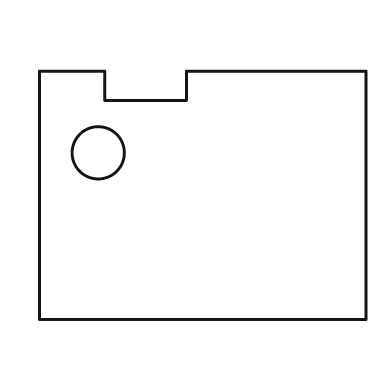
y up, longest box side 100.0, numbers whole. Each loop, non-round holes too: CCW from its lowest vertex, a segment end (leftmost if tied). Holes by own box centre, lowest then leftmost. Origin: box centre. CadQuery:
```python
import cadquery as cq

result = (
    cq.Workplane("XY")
    .moveTo(-50.0, -38.0)
    .lineTo(50.0, -38.0)
    .lineTo(50.0, 38.0)
    .lineTo(-5.0, 38.0)
    .lineTo(-5.0, 29.0)
    .lineTo(-30.0, 29.0)
    .lineTo(-30.0, 38.0)
    .lineTo(-50.0, 38.0)
    .close()
    .moveTo(-32.0, 13.0)
    .circle(8.0)
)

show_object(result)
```